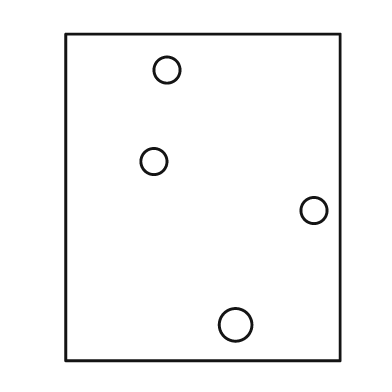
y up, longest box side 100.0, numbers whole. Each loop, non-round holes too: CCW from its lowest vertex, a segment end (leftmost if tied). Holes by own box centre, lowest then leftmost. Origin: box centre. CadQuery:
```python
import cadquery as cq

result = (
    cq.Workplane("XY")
    .moveTo(-42.0, -50.0)
    .lineTo(42.0, -50.0)
    .lineTo(42.0, 50.0)
    .lineTo(-42.0, 50.0)
    .close()
    .moveTo(10.0, -39.0)
    .circle(5.0)
    .moveTo(34.0, -4.0)
    .circle(4.0)
    .moveTo(-15.0, 11.0)
    .circle(4.0)
    .moveTo(-11.0, 39.0)
    .circle(4.0)
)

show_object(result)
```